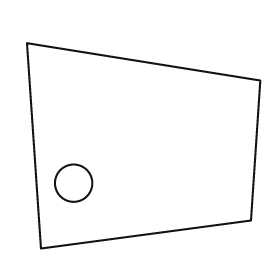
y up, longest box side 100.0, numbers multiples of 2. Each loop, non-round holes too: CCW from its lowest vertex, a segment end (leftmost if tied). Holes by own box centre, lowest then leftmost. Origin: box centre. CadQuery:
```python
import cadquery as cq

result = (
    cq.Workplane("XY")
    .moveTo(-44.0, -44.0)
    .lineTo(46.0, -32.0)
    .lineTo(50.0, 28.0)
    .lineTo(-50.0, 44.0)
    .close()
    .moveTo(-30.0, -16.0)
    .circle(8.0)
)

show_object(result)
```